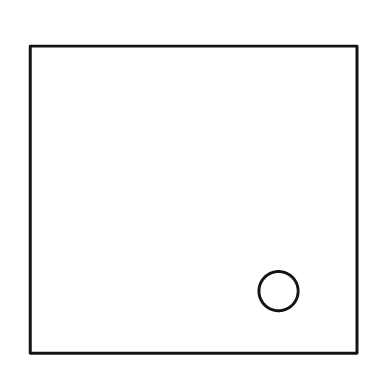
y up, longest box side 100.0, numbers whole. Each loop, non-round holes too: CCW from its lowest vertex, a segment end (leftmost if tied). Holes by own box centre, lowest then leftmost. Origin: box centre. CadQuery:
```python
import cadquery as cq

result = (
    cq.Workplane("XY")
    .moveTo(-50.0, -47.0)
    .lineTo(50.0, -47.0)
    .lineTo(50.0, 47.0)
    .lineTo(-50.0, 47.0)
    .close()
    .moveTo(26.0, -28.0)
    .circle(6.0)
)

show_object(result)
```